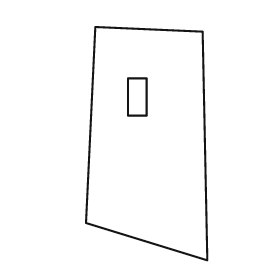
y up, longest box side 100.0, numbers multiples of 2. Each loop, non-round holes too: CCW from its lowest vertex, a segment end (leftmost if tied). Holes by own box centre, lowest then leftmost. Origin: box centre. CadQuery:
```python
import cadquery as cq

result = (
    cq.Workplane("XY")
    .moveTo(26.0, -50.0)
    .lineTo(24.0, 48.0)
    .lineTo(-22.0, 50.0)
    .lineTo(-26.0, -34.0)
    .close()
    .moveTo(-8.0, 12.0)
    .lineTo(0.0, 12.0)
    .lineTo(0.0, 28.0)
    .lineTo(-8.0, 28.0)
    .close()
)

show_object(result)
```